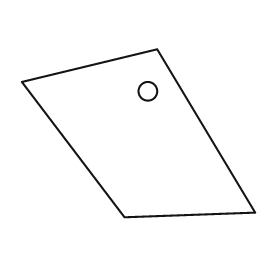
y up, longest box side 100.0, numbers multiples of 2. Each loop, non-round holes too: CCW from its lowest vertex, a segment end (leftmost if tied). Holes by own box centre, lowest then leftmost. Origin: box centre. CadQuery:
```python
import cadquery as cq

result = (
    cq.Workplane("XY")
    .moveTo(-6.0, -36.0)
    .lineTo(50.0, -34.0)
    .lineTo(8.0, 36.0)
    .lineTo(-50.0, 22.0)
    .close()
    .moveTo(4.0, 18.0)
    .circle(4.0)
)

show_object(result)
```